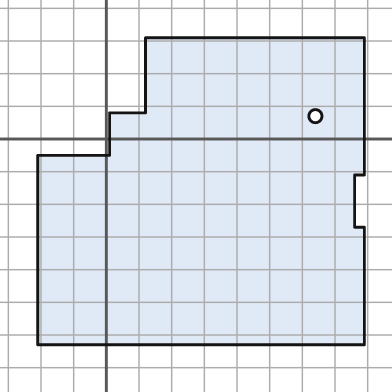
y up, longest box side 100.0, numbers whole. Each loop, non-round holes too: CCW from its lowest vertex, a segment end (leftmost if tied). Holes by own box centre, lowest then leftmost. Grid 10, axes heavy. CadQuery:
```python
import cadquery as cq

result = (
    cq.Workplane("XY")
    .moveTo(-21.0, -63.0)
    .lineTo(79.0, -63.0)
    .lineTo(79.0, -27.0)
    .lineTo(76.0, -27.0)
    .lineTo(76.0, -11.0)
    .lineTo(79.0, -11.0)
    .lineTo(79.0, 31.0)
    .lineTo(12.0, 31.0)
    .lineTo(12.0, 8.0)
    .lineTo(1.0, 8.0)
    .lineTo(1.0, -5.0)
    .lineTo(-21.0, -5.0)
    .close()
    .moveTo(64.0, 7.0)
    .circle(2.0)
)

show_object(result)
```